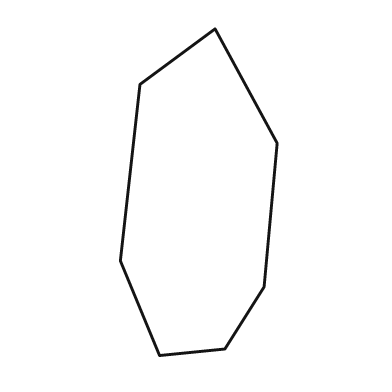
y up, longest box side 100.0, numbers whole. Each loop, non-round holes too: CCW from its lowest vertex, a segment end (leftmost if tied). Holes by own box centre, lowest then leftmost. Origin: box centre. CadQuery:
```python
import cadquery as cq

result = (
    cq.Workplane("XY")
    .moveTo(-12.0, -50.0)
    .lineTo(8.0, -48.0)
    .lineTo(20.0, -29.0)
    .lineTo(24.0, 15.0)
    .lineTo(5.0, 50.0)
    .lineTo(-18.0, 33.0)
    .lineTo(-24.0, -21.0)
    .close()
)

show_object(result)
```